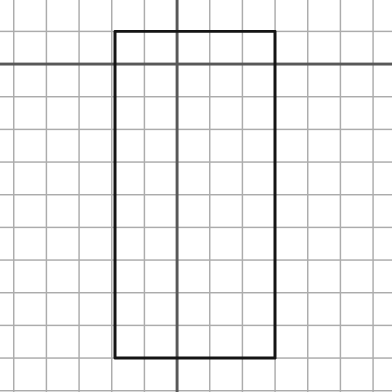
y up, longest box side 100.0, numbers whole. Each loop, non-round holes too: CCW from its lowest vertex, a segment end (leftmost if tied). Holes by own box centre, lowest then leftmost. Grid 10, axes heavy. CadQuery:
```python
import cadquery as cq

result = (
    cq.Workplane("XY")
    .moveTo(-19.0, -90.0)
    .lineTo(30.0, -90.0)
    .lineTo(30.0, 10.0)
    .lineTo(-19.0, 10.0)
    .close()
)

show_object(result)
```